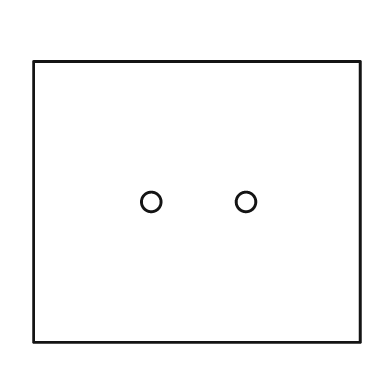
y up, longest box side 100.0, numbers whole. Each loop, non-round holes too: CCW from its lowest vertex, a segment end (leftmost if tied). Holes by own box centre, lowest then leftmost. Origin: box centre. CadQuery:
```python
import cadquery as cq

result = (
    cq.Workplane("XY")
    .moveTo(-50.0, -43.0)
    .lineTo(50.0, -43.0)
    .lineTo(50.0, 43.0)
    .lineTo(-50.0, 43.0)
    .close()
    .moveTo(-14.0, 0.0)
    .circle(3.0)
    .moveTo(15.0, 0.0)
    .circle(3.0)
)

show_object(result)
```